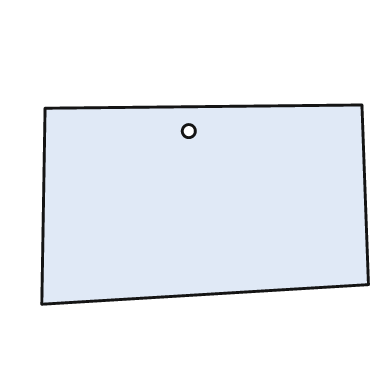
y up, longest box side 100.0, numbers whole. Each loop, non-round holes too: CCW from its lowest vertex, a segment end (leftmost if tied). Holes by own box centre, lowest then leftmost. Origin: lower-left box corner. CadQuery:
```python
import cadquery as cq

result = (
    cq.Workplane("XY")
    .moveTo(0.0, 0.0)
    .lineTo(100.0, 6.0)
    .lineTo(98.0, 61.0)
    .lineTo(1.0, 60.0)
    .close()
    .moveTo(45.0, 53.0)
    .circle(2.0)
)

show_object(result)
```